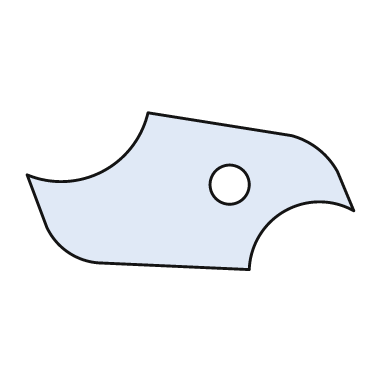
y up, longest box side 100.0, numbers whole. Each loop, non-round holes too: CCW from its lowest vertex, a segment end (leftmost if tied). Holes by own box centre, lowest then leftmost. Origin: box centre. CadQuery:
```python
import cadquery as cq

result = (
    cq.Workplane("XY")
    .moveTo(18.0, -24.0)
    .threePointArc((29.0, -6.0), (50.0, -6.0))
    .lineTo(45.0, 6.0)
    .threePointArc((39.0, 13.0), (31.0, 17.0))
    .lineTo(-13.0, 24.0)
    .threePointArc((-27.0, 6.0), (-50.0, 5.0))
    .lineTo(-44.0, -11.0)
    .threePointArc((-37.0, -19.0), (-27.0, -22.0))
    .close()
    .moveTo(12.0, 2.0)
    .circle(6.0)
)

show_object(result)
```